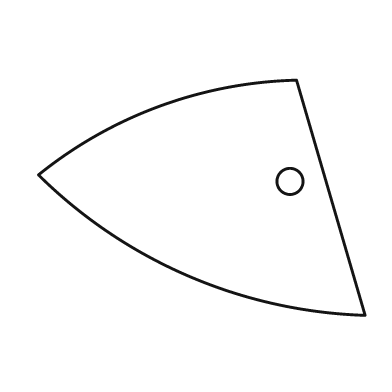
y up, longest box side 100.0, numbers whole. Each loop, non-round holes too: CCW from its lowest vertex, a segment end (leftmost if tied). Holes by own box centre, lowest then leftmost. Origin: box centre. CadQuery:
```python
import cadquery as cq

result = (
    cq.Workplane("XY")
    .moveTo(50.0, -36.0)
    .lineTo(29.0, 36.0)
    .threePointArc((-13.0, 28.0), (-50.0, 7.0))
    .threePointArc((-4.0, -24.0), (50.0, -36.0))
    .close()
    .moveTo(27.0, 5.0)
    .circle(4.0)
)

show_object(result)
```